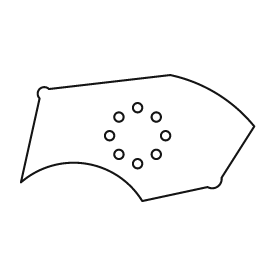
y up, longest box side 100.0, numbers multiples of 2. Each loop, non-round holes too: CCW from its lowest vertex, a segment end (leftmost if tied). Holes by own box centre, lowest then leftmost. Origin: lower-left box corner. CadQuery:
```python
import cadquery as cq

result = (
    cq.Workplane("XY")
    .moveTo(52.0, 0.0)
    .lineTo(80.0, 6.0)
    .threePointArc((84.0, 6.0), (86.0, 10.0))
    .lineTo(100.0, 32.0)
    .threePointArc((84.0, 46.0), (64.0, 54.0))
    .lineTo(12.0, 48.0)
    .threePointArc((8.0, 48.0), (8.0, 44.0))
    .lineTo(0.0, 8.0)
    .threePointArc((28.0, 16.0), (52.0, 0.0))
    .close()
    .moveTo(50.0, 16.0)
    .circle(2.0)
    .moveTo(42.0, 20.0)
    .circle(2.0)
    .moveTo(58.0, 20.0)
    .circle(2.0)
    .moveTo(38.0, 28.0)
    .circle(2.0)
    .moveTo(62.0, 28.0)
    .circle(2.0)
    .moveTo(42.0, 36.0)
    .circle(2.0)
    .moveTo(58.0, 36.0)
    .circle(2.0)
    .moveTo(50.0, 40.0)
    .circle(2.0)
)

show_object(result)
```